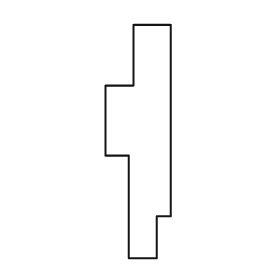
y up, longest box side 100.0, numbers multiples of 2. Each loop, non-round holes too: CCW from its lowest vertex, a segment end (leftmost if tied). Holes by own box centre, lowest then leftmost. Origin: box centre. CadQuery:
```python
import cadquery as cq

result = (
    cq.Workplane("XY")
    .moveTo(-4.0, -50.0)
    .lineTo(8.0, -50.0)
    .lineTo(8.0, -32.0)
    .lineTo(14.0, -32.0)
    .lineTo(14.0, 50.0)
    .lineTo(-2.0, 50.0)
    .lineTo(-2.0, 24.0)
    .lineTo(-14.0, 24.0)
    .lineTo(-14.0, -6.0)
    .lineTo(-4.0, -6.0)
    .close()
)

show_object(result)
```